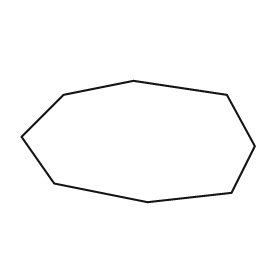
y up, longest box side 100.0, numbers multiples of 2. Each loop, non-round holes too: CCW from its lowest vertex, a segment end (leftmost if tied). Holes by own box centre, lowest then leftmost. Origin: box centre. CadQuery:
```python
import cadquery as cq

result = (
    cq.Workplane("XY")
    .moveTo(4.0, -26.0)
    .lineTo(40.0, -22.0)
    .lineTo(50.0, -2.0)
    .lineTo(38.0, 20.0)
    .lineTo(-2.0, 26.0)
    .lineTo(-32.0, 20.0)
    .lineTo(-50.0, 2.0)
    .lineTo(-36.0, -18.0)
    .close()
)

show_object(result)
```